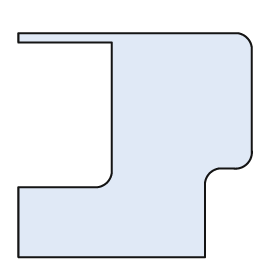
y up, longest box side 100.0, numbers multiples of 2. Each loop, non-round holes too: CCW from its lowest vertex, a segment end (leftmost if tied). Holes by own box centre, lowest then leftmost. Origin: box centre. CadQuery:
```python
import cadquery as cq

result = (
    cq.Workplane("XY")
    .moveTo(-50.0, -48.0)
    .lineTo(30.0, -48.0)
    .lineTo(30.0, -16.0)
    .threePointArc((32.0, -12.0), (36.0, -10.0))
    .lineTo(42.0, -10.0)
    .threePointArc((48.0, -8.0), (50.0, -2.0))
    .lineTo(50.0, 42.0)
    .threePointArc((48.0, 46.0), (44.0, 48.0))
    .lineTo(-50.0, 48.0)
    .lineTo(-50.0, 44.0)
    .lineTo(-10.0, 44.0)
    .lineTo(-10.0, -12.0)
    .threePointArc((-12.0, -16.0), (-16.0, -18.0))
    .lineTo(-50.0, -18.0)
    .close()
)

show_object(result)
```